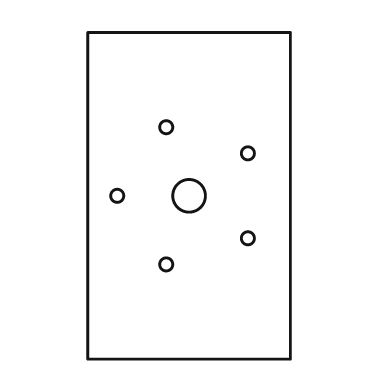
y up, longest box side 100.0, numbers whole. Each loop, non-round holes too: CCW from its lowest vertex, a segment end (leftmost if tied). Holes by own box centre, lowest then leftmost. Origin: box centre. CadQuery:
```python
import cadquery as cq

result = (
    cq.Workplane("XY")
    .moveTo(-31.0, -50.0)
    .lineTo(31.0, -50.0)
    .lineTo(31.0, 50.0)
    .lineTo(-31.0, 50.0)
    .close()
    .moveTo(-7.0, -21.0)
    .circle(2.0)
    .moveTo(18.0, -13.0)
    .circle(2.0)
    .moveTo(-22.0, 0.0)
    .circle(2.0)
    .moveTo(0.0, 0.0)
    .circle(5.0)
    .moveTo(18.0, 13.0)
    .circle(2.0)
    .moveTo(-7.0, 21.0)
    .circle(2.0)
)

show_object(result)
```